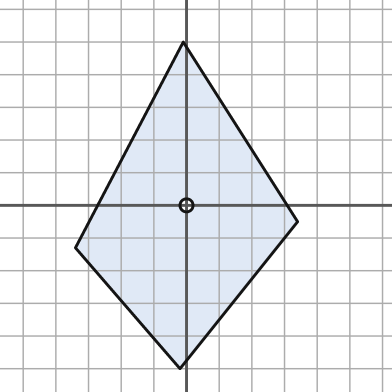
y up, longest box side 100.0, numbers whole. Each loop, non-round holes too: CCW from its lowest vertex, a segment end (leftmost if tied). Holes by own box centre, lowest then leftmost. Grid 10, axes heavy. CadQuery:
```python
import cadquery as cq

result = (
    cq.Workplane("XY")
    .moveTo(-2.0, -50.0)
    .lineTo(34.0, -5.0)
    .lineTo(-1.0, 50.0)
    .lineTo(-34.0, -13.0)
    .close()
    .moveTo(0.0, 0.0)
    .circle(2.0)
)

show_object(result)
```